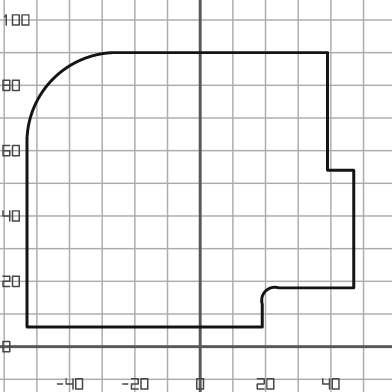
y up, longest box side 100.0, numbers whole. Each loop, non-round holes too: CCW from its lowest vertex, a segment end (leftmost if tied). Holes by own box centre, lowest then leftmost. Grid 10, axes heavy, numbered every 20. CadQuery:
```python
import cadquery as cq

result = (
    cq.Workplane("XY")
    .moveTo(-53.0, 6.0)
    .lineTo(19.0, 6.0)
    .lineTo(19.0, 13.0)
    .threePointArc((20.0, 17.0), (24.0, 18.0))
    .lineTo(47.0, 18.0)
    .lineTo(47.0, 54.0)
    .lineTo(39.0, 54.0)
    .lineTo(39.0, 90.0)
    .lineTo(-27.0, 90.0)
    .threePointArc((-45.0, 82.0), (-53.0, 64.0))
    .close()
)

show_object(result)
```